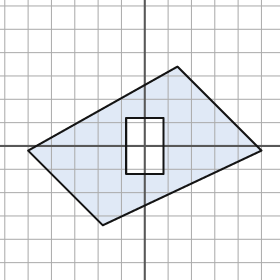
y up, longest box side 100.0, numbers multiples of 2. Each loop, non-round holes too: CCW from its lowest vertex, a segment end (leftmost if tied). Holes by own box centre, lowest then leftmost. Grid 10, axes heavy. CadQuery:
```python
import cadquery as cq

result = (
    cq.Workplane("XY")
    .moveTo(-18.0, -34.0)
    .lineTo(50.0, -2.0)
    .lineTo(14.0, 34.0)
    .lineTo(-50.0, -2.0)
    .close()
    .moveTo(-8.0, -12.0)
    .lineTo(8.0, -12.0)
    .lineTo(8.0, 12.0)
    .lineTo(-8.0, 12.0)
    .close()
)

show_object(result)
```